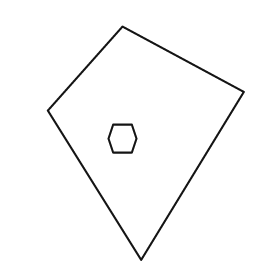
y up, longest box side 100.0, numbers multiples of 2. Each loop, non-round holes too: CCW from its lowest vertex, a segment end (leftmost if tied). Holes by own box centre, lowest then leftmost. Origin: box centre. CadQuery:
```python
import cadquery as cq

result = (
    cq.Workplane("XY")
    .moveTo(-2.0, -50.0)
    .lineTo(42.0, 22.0)
    .lineTo(-10.0, 50.0)
    .lineTo(-42.0, 14.0)
    .close()
    .moveTo(-14.0, -4.0)
    .lineTo(-6.0, -4.0)
    .lineTo(-4.0, 2.0)
    .lineTo(-6.0, 8.0)
    .lineTo(-14.0, 8.0)
    .lineTo(-16.0, 2.0)
    .close()
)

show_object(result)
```